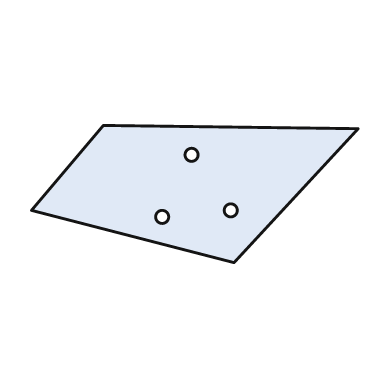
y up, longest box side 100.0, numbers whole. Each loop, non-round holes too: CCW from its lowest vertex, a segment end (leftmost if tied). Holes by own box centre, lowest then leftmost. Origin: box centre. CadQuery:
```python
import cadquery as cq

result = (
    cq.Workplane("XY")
    .moveTo(12.0, -21.0)
    .lineTo(50.0, 20.0)
    .lineTo(-28.0, 21.0)
    .lineTo(-50.0, -5.0)
    .close()
    .moveTo(-10.0, -7.0)
    .circle(2.0)
    .moveTo(11.0, -5.0)
    .circle(2.0)
    .moveTo(-1.0, 12.0)
    .circle(2.0)
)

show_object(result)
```